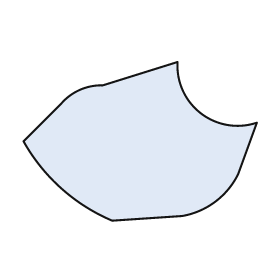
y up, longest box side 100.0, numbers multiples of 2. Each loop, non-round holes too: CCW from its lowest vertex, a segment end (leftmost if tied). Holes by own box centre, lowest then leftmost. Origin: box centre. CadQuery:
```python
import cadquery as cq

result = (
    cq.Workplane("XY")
    .moveTo(-12.0, -34.0)
    .lineTo(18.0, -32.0)
    .threePointArc((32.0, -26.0), (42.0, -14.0))
    .lineTo(50.0, 8.0)
    .threePointArc((26.0, 12.0), (16.0, 34.0))
    .lineTo(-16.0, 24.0)
    .threePointArc((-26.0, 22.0), (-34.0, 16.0))
    .lineTo(-50.0, 0.0)
    .threePointArc((-34.0, -20.0), (-12.0, -34.0))
    .close()
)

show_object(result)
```